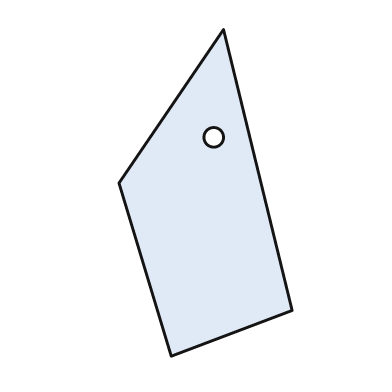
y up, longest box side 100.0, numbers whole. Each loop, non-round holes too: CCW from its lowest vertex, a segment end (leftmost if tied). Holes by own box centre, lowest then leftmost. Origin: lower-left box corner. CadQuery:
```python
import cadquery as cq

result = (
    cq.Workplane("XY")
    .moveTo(16.0, 0.0)
    .lineTo(53.0, 14.0)
    .lineTo(32.0, 100.0)
    .lineTo(0.0, 53.0)
    .close()
    .moveTo(29.0, 67.0)
    .circle(3.0)
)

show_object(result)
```